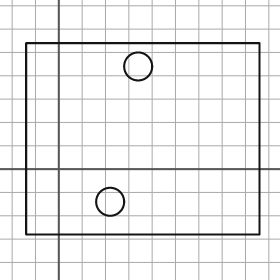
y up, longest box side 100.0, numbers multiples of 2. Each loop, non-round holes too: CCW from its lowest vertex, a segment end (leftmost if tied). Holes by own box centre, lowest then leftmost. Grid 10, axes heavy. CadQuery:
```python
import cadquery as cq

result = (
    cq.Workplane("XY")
    .moveTo(-14.0, -28.0)
    .lineTo(86.0, -28.0)
    .lineTo(86.0, 54.0)
    .lineTo(-14.0, 54.0)
    .close()
    .moveTo(22.0, -14.0)
    .circle(6.0)
    .moveTo(34.0, 44.0)
    .circle(6.0)
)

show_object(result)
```